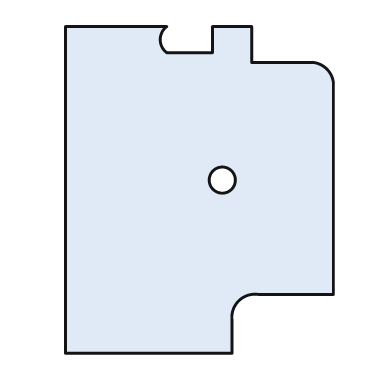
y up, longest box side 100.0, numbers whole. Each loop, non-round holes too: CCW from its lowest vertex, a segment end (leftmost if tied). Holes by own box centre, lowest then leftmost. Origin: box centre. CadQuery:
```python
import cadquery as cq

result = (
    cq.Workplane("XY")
    .moveTo(-41.0, -50.0)
    .lineTo(10.0, -50.0)
    .lineTo(10.0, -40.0)
    .threePointArc((12.0, -34.0), (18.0, -32.0))
    .lineTo(41.0, -32.0)
    .lineTo(41.0, 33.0)
    .threePointArc((39.0, 37.0), (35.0, 39.0))
    .lineTo(16.0, 39.0)
    .lineTo(16.0, 50.0)
    .lineTo(4.0, 50.0)
    .lineTo(4.0, 42.0)
    .lineTo(-10.0, 42.0)
    .threePointArc((-12.0, 46.0), (-10.0, 50.0))
    .lineTo(-41.0, 50.0)
    .close()
    .moveTo(7.0, 3.0)
    .circle(4.0)
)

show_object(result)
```